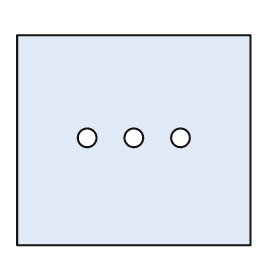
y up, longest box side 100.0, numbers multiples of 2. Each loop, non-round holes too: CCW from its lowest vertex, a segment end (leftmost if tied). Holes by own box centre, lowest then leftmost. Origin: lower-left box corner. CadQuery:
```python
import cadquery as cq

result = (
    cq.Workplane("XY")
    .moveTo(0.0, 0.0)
    .lineTo(100.0, 0.0)
    .lineTo(100.0, 90.0)
    .lineTo(0.0, 90.0)
    .close()
    .moveTo(30.0, 46.0)
    .circle(4.0)
    .moveTo(50.0, 46.0)
    .circle(4.0)
    .moveTo(70.0, 46.0)
    .circle(4.0)
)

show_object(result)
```